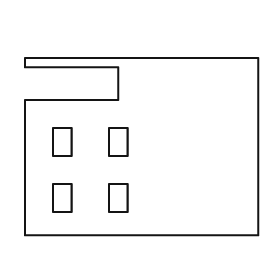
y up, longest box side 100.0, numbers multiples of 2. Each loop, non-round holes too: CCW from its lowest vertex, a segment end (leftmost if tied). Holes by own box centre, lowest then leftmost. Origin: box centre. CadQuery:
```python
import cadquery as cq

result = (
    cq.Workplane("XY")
    .moveTo(-50.0, -38.0)
    .lineTo(50.0, -38.0)
    .lineTo(50.0, 38.0)
    .lineTo(-50.0, 38.0)
    .lineTo(-50.0, 34.0)
    .lineTo(-10.0, 34.0)
    .lineTo(-10.0, 20.0)
    .lineTo(-50.0, 20.0)
    .close()
    .moveTo(-38.0, -28.0)
    .lineTo(-30.0, -28.0)
    .lineTo(-30.0, -16.0)
    .lineTo(-38.0, -16.0)
    .close()
    .moveTo(-14.0, -28.0)
    .lineTo(-6.0, -28.0)
    .lineTo(-6.0, -16.0)
    .lineTo(-14.0, -16.0)
    .close()
    .moveTo(-38.0, -4.0)
    .lineTo(-30.0, -4.0)
    .lineTo(-30.0, 8.0)
    .lineTo(-38.0, 8.0)
    .close()
    .moveTo(-14.0, -4.0)
    .lineTo(-6.0, -4.0)
    .lineTo(-6.0, 8.0)
    .lineTo(-14.0, 8.0)
    .close()
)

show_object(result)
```